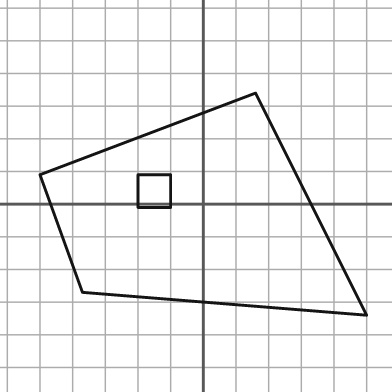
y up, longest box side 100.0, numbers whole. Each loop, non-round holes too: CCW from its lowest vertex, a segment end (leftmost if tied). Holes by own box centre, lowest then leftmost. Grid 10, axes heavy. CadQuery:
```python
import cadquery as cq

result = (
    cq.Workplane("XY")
    .moveTo(50.0, -34.0)
    .lineTo(16.0, 34.0)
    .lineTo(-50.0, 9.0)
    .lineTo(-37.0, -27.0)
    .close()
    .moveTo(-20.0, -1.0)
    .lineTo(-10.0, -1.0)
    .lineTo(-10.0, 9.0)
    .lineTo(-20.0, 9.0)
    .close()
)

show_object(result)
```